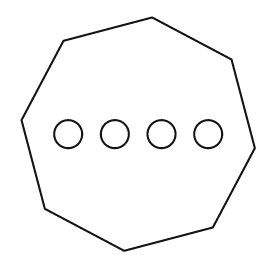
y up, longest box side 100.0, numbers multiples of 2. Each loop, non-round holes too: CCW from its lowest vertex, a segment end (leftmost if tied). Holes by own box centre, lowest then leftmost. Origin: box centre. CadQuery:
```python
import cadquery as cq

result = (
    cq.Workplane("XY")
    .moveTo(-6.0, -50.0)
    .lineTo(32.0, -40.0)
    .lineTo(50.0, -6.0)
    .lineTo(40.0, 32.0)
    .lineTo(6.0, 50.0)
    .lineTo(-32.0, 40.0)
    .lineTo(-50.0, 6.0)
    .lineTo(-40.0, -32.0)
    .close()
    .moveTo(-30.0, 0.0)
    .circle(6.0)
    .moveTo(-10.0, 0.0)
    .circle(6.0)
    .moveTo(10.0, 0.0)
    .circle(6.0)
    .moveTo(30.0, 0.0)
    .circle(6.0)
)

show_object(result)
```